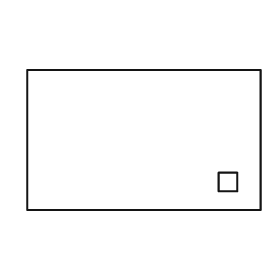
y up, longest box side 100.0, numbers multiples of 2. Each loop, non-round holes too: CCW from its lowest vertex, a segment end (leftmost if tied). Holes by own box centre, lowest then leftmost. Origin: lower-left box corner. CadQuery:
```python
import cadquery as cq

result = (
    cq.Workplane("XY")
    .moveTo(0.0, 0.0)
    .lineTo(100.0, 0.0)
    .lineTo(100.0, 60.0)
    .lineTo(0.0, 60.0)
    .close()
    .moveTo(82.0, 8.0)
    .lineTo(90.0, 8.0)
    .lineTo(90.0, 16.0)
    .lineTo(82.0, 16.0)
    .close()
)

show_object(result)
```